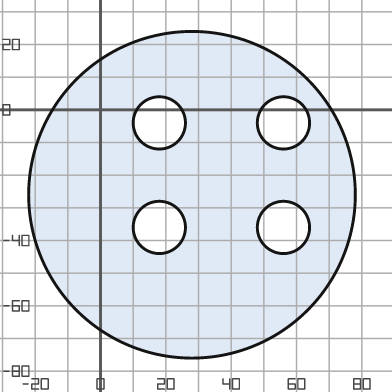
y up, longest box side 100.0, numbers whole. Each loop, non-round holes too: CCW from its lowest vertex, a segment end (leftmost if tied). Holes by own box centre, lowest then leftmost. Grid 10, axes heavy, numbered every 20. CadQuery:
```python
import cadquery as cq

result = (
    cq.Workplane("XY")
    .moveTo(28.0, -26.0)
    .circle(50.0)
    .moveTo(18.0, -36.0)
    .circle(8.0)
    .moveTo(56.0, -36.0)
    .circle(8.0)
    .moveTo(18.0, -4.0)
    .circle(8.0)
    .moveTo(56.0, -4.0)
    .circle(8.0)
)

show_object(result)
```